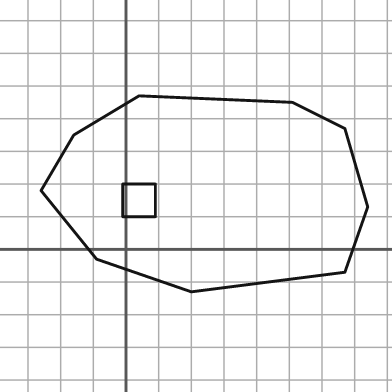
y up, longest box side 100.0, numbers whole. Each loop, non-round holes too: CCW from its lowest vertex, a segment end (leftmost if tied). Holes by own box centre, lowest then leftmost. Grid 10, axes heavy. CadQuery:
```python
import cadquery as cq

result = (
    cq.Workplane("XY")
    .moveTo(20.0, -13.0)
    .lineTo(67.0, -7.0)
    .lineTo(74.0, 13.0)
    .lineTo(67.0, 37.0)
    .lineTo(51.0, 45.0)
    .lineTo(4.0, 47.0)
    .lineTo(-16.0, 35.0)
    .lineTo(-26.0, 18.0)
    .lineTo(-9.0, -3.0)
    .close()
    .moveTo(-1.0, 10.0)
    .lineTo(9.0, 10.0)
    .lineTo(9.0, 20.0)
    .lineTo(-1.0, 20.0)
    .close()
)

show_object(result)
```